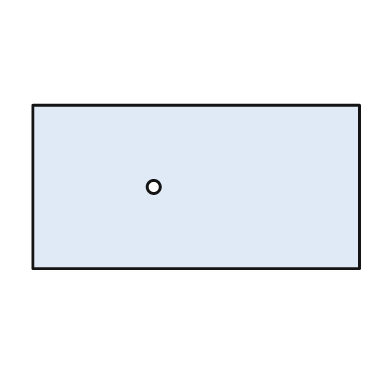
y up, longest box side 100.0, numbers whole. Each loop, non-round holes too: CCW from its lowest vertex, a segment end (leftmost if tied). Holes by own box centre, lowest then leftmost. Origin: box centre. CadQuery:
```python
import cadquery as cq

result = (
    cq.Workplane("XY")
    .moveTo(-50.0, -25.0)
    .lineTo(50.0, -25.0)
    .lineTo(50.0, 25.0)
    .lineTo(-50.0, 25.0)
    .close()
    .moveTo(-13.0, 0.0)
    .circle(2.0)
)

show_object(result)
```